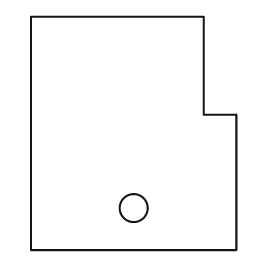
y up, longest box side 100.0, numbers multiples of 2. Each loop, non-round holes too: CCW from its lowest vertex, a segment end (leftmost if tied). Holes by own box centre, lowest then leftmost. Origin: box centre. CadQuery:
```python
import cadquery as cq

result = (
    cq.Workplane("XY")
    .moveTo(-44.0, -50.0)
    .lineTo(44.0, -50.0)
    .lineTo(44.0, 8.0)
    .lineTo(30.0, 8.0)
    .lineTo(30.0, 50.0)
    .lineTo(-44.0, 50.0)
    .close()
    .moveTo(0.0, -32.0)
    .circle(6.0)
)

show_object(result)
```